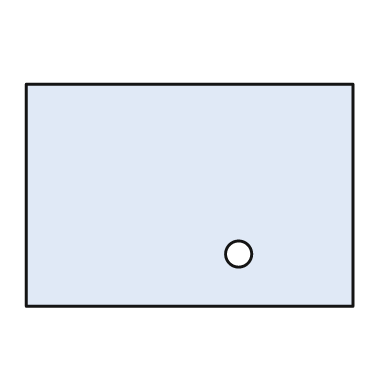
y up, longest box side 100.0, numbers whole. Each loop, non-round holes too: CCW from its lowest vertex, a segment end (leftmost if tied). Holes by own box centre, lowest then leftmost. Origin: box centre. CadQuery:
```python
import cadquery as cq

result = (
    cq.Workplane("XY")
    .moveTo(-50.0, -34.0)
    .lineTo(50.0, -34.0)
    .lineTo(50.0, 34.0)
    .lineTo(-50.0, 34.0)
    .close()
    .moveTo(15.0, -18.0)
    .circle(4.0)
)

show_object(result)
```